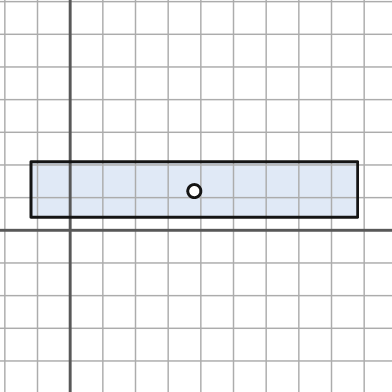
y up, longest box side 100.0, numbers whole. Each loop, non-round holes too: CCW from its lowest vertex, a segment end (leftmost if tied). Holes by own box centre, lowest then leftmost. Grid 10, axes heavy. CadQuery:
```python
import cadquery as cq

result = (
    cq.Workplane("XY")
    .moveTo(-12.0, 4.0)
    .lineTo(88.0, 4.0)
    .lineTo(88.0, 21.0)
    .lineTo(-12.0, 21.0)
    .close()
    .moveTo(38.0, 12.0)
    .circle(2.0)
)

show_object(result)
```